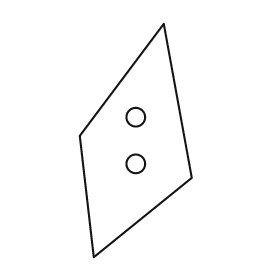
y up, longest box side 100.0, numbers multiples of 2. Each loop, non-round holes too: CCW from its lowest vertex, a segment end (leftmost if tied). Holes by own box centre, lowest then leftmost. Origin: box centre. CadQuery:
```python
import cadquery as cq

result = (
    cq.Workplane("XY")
    .moveTo(-18.0, -50.0)
    .lineTo(24.0, -16.0)
    .lineTo(12.0, 50.0)
    .lineTo(-24.0, 2.0)
    .close()
    .moveTo(0.0, -10.0)
    .circle(4.0)
    .moveTo(0.0, 10.0)
    .circle(4.0)
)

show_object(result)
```